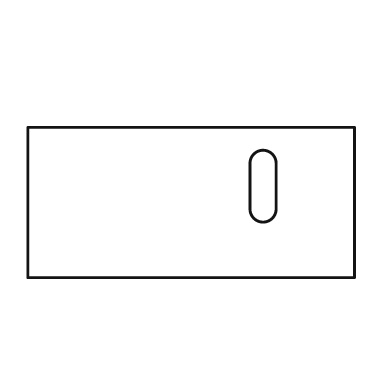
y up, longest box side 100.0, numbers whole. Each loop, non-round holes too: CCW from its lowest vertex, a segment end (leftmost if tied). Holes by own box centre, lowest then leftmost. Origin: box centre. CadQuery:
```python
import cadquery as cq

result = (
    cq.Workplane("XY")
    .moveTo(-50.0, -23.0)
    .lineTo(50.0, -23.0)
    .lineTo(50.0, 23.0)
    .lineTo(-50.0, 23.0)
    .close()
    .moveTo(18.0, -2.0)
    .threePointArc((22.0, -6.0), (26.0, -2.0))
    .lineTo(26.0, 12.0)
    .threePointArc((22.0, 16.0), (18.0, 12.0))
    .close()
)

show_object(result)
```